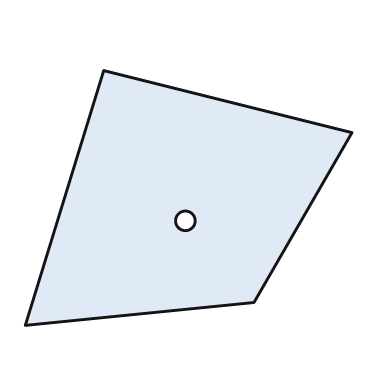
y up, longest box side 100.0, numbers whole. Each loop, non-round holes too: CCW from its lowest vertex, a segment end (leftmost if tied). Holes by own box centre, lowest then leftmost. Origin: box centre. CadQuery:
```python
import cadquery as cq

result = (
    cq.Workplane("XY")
    .moveTo(-50.0, -39.0)
    .lineTo(20.0, -32.0)
    .lineTo(50.0, 20.0)
    .lineTo(-26.0, 39.0)
    .close()
    .moveTo(-1.0, -7.0)
    .circle(3.0)
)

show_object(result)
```